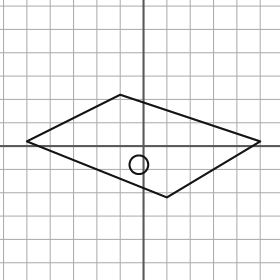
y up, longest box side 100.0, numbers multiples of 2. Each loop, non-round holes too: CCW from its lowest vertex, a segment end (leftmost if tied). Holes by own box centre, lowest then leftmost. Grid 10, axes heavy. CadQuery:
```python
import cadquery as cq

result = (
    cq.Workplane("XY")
    .moveTo(10.0, -22.0)
    .lineTo(50.0, 2.0)
    .lineTo(-10.0, 22.0)
    .lineTo(-50.0, 2.0)
    .close()
    .moveTo(-2.0, -8.0)
    .circle(4.0)
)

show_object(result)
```